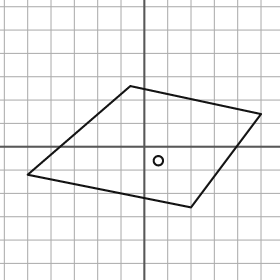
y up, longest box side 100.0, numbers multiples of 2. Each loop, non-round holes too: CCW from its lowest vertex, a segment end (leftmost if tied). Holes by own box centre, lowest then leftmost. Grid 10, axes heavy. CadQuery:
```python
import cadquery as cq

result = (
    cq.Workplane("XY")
    .moveTo(20.0, -26.0)
    .lineTo(50.0, 14.0)
    .lineTo(-6.0, 26.0)
    .lineTo(-50.0, -12.0)
    .close()
    .moveTo(6.0, -6.0)
    .circle(2.0)
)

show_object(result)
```